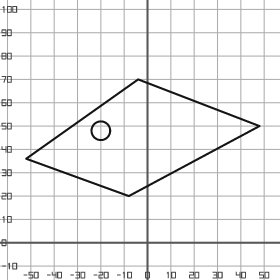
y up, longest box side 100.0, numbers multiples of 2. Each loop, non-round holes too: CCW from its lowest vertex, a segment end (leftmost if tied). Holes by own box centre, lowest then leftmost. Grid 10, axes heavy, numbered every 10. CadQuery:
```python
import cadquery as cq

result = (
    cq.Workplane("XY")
    .moveTo(-8.0, 20.0)
    .lineTo(48.0, 50.0)
    .lineTo(-4.0, 70.0)
    .lineTo(-52.0, 36.0)
    .close()
    .moveTo(-20.0, 48.0)
    .circle(4.0)
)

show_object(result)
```